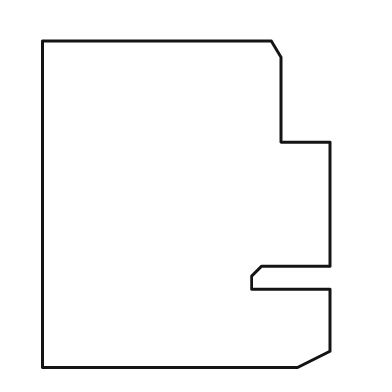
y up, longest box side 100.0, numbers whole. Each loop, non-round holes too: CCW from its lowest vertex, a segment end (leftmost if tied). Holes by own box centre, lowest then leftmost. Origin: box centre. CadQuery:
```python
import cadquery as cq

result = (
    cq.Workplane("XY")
    .moveTo(-44.0, -50.0)
    .lineTo(34.0, -50.0)
    .lineTo(44.0, -45.0)
    .lineTo(44.0, -26.0)
    .lineTo(20.0, -26.0)
    .lineTo(20.0, -22.0)
    .lineTo(23.0, -19.0)
    .lineTo(44.0, -19.0)
    .lineTo(44.0, 19.0)
    .lineTo(29.0, 19.0)
    .lineTo(29.0, 45.0)
    .lineTo(26.0, 50.0)
    .lineTo(-44.0, 50.0)
    .close()
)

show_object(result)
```